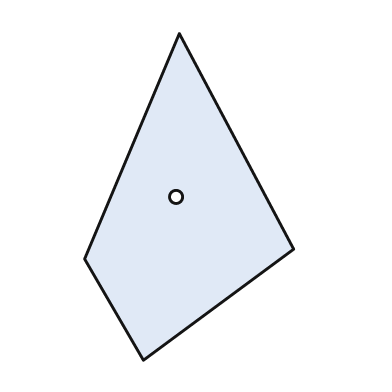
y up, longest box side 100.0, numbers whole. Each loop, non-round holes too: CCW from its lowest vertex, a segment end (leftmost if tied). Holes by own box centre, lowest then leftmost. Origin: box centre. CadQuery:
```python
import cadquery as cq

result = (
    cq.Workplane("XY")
    .moveTo(-14.0, -50.0)
    .lineTo(32.0, -16.0)
    .lineTo(-3.0, 50.0)
    .lineTo(-32.0, -19.0)
    .close()
    .moveTo(-4.0, 0.0)
    .circle(2.0)
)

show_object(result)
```